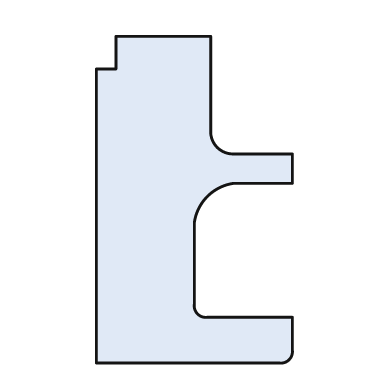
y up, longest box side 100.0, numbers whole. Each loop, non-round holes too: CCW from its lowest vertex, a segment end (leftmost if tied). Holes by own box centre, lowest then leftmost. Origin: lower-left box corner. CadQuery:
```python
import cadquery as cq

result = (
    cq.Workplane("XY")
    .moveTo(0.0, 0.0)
    .lineTo(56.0, 0.0)
    .threePointArc((59.0, 1.0), (60.0, 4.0))
    .lineTo(60.0, 14.0)
    .lineTo(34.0, 14.0)
    .threePointArc((31.0, 15.0), (30.0, 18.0))
    .lineTo(30.0, 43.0)
    .threePointArc((34.0, 51.0), (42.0, 55.0))
    .lineTo(60.0, 55.0)
    .lineTo(60.0, 64.0)
    .lineTo(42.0, 64.0)
    .threePointArc((37.0, 66.0), (35.0, 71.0))
    .lineTo(35.0, 100.0)
    .lineTo(6.0, 100.0)
    .lineTo(6.0, 90.0)
    .lineTo(0.0, 90.0)
    .close()
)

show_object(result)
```